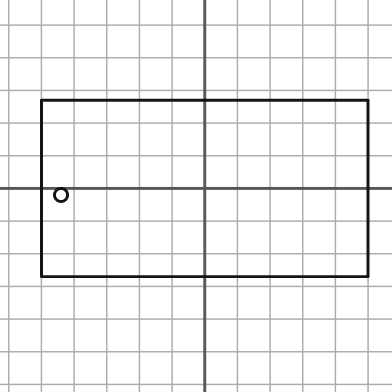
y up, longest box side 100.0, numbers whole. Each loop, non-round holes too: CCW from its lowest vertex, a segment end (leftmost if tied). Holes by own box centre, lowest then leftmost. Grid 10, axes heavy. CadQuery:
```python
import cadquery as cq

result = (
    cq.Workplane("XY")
    .moveTo(-50.0, -27.0)
    .lineTo(50.0, -27.0)
    .lineTo(50.0, 27.0)
    .lineTo(-50.0, 27.0)
    .close()
    .moveTo(-44.0, -2.0)
    .circle(2.0)
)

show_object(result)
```